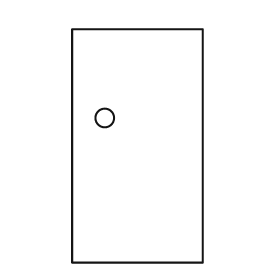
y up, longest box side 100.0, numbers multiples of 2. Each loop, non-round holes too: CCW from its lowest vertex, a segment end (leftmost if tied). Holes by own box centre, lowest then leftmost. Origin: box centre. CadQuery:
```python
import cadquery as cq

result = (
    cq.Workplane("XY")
    .moveTo(-28.0, -50.0)
    .lineTo(28.0, -50.0)
    .lineTo(28.0, 50.0)
    .lineTo(-28.0, 50.0)
    .close()
    .moveTo(-14.0, 12.0)
    .circle(4.0)
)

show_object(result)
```